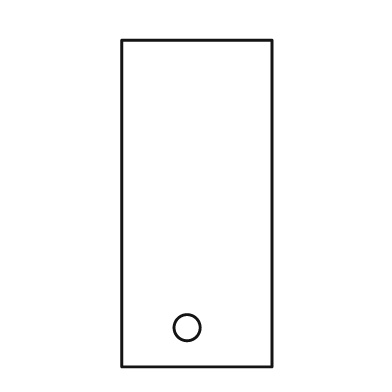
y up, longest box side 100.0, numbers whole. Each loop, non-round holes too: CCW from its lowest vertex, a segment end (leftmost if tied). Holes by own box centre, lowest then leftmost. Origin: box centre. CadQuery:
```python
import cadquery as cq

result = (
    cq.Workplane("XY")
    .moveTo(-23.0, -50.0)
    .lineTo(23.0, -50.0)
    .lineTo(23.0, 50.0)
    .lineTo(-23.0, 50.0)
    .close()
    .moveTo(-3.0, -38.0)
    .circle(4.0)
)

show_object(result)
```